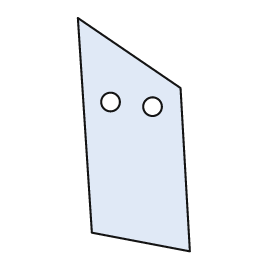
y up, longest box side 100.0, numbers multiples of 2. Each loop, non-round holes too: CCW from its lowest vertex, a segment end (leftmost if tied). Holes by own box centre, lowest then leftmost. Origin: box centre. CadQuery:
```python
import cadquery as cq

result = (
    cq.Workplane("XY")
    .moveTo(24.0, -50.0)
    .lineTo(20.0, 20.0)
    .lineTo(-24.0, 50.0)
    .lineTo(-18.0, -42.0)
    .close()
    .moveTo(8.0, 12.0)
    .circle(4.0)
    .moveTo(-10.0, 14.0)
    .circle(4.0)
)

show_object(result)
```